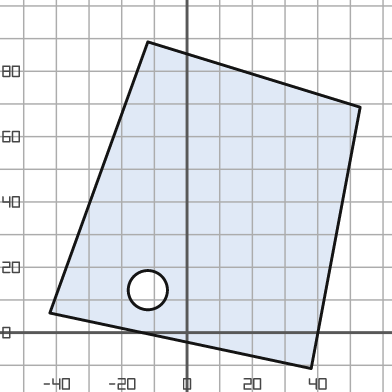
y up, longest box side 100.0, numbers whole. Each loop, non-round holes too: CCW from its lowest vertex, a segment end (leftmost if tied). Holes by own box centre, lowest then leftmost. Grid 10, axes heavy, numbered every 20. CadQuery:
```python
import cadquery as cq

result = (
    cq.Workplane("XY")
    .moveTo(38.0, -11.0)
    .lineTo(53.0, 69.0)
    .lineTo(-12.0, 89.0)
    .lineTo(-42.0, 6.0)
    .close()
    .moveTo(-12.0, 13.0)
    .circle(6.0)
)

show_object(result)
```